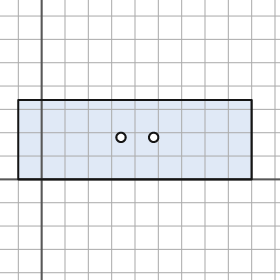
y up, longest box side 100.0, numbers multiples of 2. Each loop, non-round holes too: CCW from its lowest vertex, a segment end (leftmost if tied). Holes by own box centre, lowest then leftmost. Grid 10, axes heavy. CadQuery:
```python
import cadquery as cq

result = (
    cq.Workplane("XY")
    .moveTo(-10.0, 0.0)
    .lineTo(90.0, 0.0)
    .lineTo(90.0, 34.0)
    .lineTo(-10.0, 34.0)
    .close()
    .moveTo(34.0, 18.0)
    .circle(2.0)
    .moveTo(48.0, 18.0)
    .circle(2.0)
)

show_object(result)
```